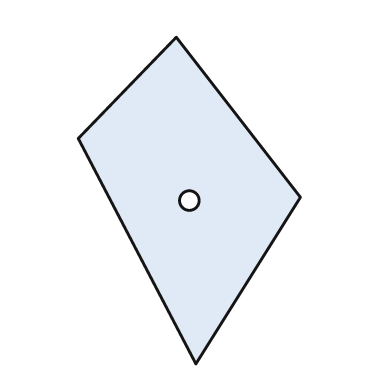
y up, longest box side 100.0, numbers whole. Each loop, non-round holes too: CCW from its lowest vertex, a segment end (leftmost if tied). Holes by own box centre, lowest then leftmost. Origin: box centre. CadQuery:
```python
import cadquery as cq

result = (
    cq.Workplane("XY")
    .moveTo(2.0, -50.0)
    .lineTo(34.0, 1.0)
    .lineTo(-4.0, 50.0)
    .lineTo(-34.0, 19.0)
    .close()
    .moveTo(0.0, 0.0)
    .circle(3.0)
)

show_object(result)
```